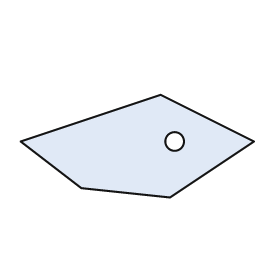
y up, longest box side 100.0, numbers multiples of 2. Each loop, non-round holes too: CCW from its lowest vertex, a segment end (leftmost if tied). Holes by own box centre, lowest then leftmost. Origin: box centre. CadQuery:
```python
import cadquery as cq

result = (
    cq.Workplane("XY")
    .moveTo(14.0, -22.0)
    .lineTo(50.0, 2.0)
    .lineTo(10.0, 22.0)
    .lineTo(-50.0, 2.0)
    .lineTo(-24.0, -18.0)
    .close()
    .moveTo(16.0, 2.0)
    .circle(4.0)
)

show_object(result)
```